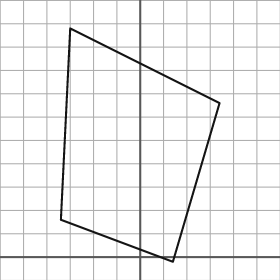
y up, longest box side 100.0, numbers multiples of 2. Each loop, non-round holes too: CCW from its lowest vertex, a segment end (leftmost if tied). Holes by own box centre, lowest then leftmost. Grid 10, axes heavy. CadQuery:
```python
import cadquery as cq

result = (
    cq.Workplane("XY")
    .moveTo(14.0, -2.0)
    .lineTo(34.0, 66.0)
    .lineTo(-30.0, 98.0)
    .lineTo(-34.0, 16.0)
    .close()
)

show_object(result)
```